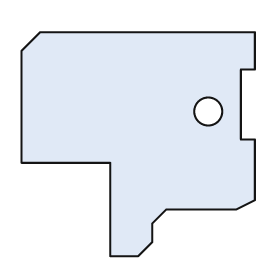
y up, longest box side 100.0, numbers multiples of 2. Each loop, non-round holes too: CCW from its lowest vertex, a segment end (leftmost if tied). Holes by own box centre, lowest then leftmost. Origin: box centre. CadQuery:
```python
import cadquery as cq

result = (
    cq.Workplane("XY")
    .moveTo(-12.0, -48.0)
    .lineTo(0.0, -48.0)
    .lineTo(6.0, -42.0)
    .lineTo(6.0, -34.0)
    .lineTo(12.0, -28.0)
    .lineTo(42.0, -28.0)
    .lineTo(50.0, -24.0)
    .lineTo(50.0, 2.0)
    .lineTo(44.0, 2.0)
    .lineTo(44.0, 32.0)
    .lineTo(50.0, 32.0)
    .lineTo(50.0, 48.0)
    .lineTo(-42.0, 48.0)
    .lineTo(-50.0, 40.0)
    .lineTo(-50.0, -8.0)
    .lineTo(-12.0, -8.0)
    .close()
    .moveTo(30.0, 14.0)
    .circle(6.0)
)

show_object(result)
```